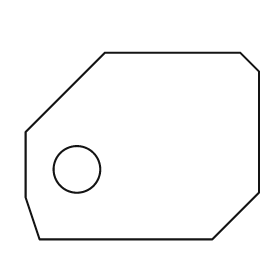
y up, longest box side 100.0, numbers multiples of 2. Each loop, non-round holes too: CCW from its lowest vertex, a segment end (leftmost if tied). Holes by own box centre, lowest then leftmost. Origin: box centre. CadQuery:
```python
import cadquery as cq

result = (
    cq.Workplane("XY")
    .moveTo(-44.0, -40.0)
    .lineTo(30.0, -40.0)
    .lineTo(50.0, -20.0)
    .lineTo(50.0, 32.0)
    .lineTo(42.0, 40.0)
    .lineTo(-16.0, 40.0)
    .lineTo(-50.0, 6.0)
    .lineTo(-50.0, -22.0)
    .close()
    .moveTo(-28.0, -10.0)
    .circle(10.0)
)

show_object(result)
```